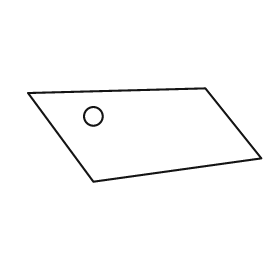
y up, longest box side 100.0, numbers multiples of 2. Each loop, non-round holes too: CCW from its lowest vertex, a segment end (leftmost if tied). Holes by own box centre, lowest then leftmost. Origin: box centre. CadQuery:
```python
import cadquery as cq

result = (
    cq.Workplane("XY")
    .moveTo(-22.0, -20.0)
    .lineTo(50.0, -10.0)
    .lineTo(26.0, 20.0)
    .lineTo(-50.0, 18.0)
    .close()
    .moveTo(-22.0, 8.0)
    .circle(4.0)
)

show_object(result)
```